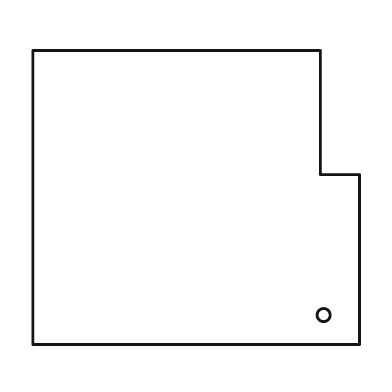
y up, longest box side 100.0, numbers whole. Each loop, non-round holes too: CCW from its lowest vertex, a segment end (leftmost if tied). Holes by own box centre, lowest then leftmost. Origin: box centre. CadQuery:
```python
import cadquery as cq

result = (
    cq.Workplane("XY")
    .moveTo(-50.0, -45.0)
    .lineTo(50.0, -45.0)
    .lineTo(50.0, 7.0)
    .lineTo(38.0, 7.0)
    .lineTo(38.0, 45.0)
    .lineTo(-50.0, 45.0)
    .close()
    .moveTo(39.0, -36.0)
    .circle(2.0)
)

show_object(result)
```